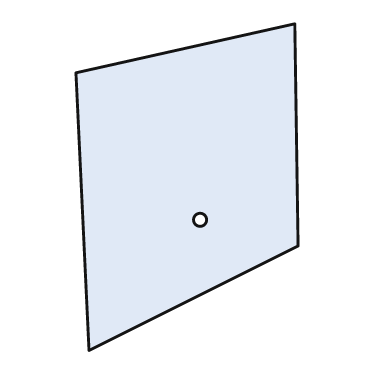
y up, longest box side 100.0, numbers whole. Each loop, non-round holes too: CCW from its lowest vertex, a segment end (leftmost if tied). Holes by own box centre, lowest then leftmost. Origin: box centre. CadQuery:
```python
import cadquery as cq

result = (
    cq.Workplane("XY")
    .moveTo(-30.0, -50.0)
    .lineTo(34.0, -18.0)
    .lineTo(33.0, 50.0)
    .lineTo(-34.0, 35.0)
    .close()
    .moveTo(4.0, -10.0)
    .circle(2.0)
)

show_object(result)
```